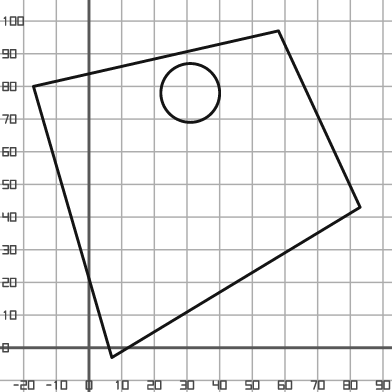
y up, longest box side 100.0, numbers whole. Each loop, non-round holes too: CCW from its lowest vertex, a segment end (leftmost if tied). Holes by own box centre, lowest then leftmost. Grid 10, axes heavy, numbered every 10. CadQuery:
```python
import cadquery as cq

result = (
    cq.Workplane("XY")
    .moveTo(7.0, -3.0)
    .lineTo(83.0, 43.0)
    .lineTo(58.0, 97.0)
    .lineTo(-17.0, 80.0)
    .close()
    .moveTo(31.0, 78.0)
    .circle(9.0)
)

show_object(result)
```